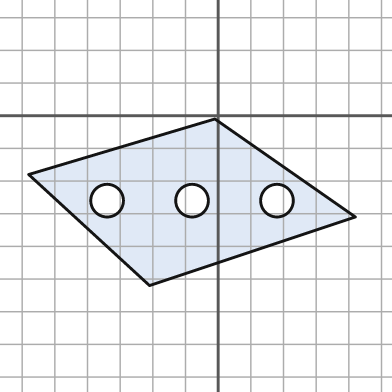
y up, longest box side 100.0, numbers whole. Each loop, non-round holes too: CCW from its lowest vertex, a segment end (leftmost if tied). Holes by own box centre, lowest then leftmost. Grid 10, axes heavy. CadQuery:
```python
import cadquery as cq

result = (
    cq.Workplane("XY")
    .moveTo(-21.0, -52.0)
    .lineTo(42.0, -31.0)
    .lineTo(-1.0, -1.0)
    .lineTo(-58.0, -18.0)
    .close()
    .moveTo(-34.0, -26.0)
    .circle(5.0)
    .moveTo(-8.0, -26.0)
    .circle(5.0)
    .moveTo(18.0, -26.0)
    .circle(5.0)
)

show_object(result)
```